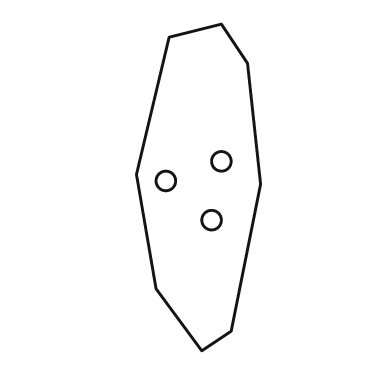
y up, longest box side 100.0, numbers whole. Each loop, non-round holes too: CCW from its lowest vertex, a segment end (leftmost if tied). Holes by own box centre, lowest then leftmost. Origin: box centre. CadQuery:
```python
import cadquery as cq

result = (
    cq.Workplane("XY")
    .moveTo(1.0, -50.0)
    .lineTo(10.0, -44.0)
    .lineTo(19.0, 1.0)
    .lineTo(15.0, 38.0)
    .lineTo(7.0, 50.0)
    .lineTo(-9.0, 46.0)
    .lineTo(-19.0, 4.0)
    .lineTo(-13.0, -31.0)
    .close()
    .moveTo(4.0, -10.0)
    .circle(3.0)
    .moveTo(-10.0, 2.0)
    .circle(3.0)
    .moveTo(7.0, 8.0)
    .circle(3.0)
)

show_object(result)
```